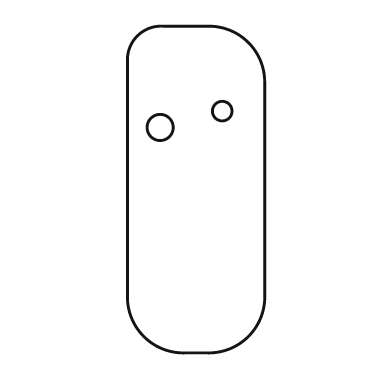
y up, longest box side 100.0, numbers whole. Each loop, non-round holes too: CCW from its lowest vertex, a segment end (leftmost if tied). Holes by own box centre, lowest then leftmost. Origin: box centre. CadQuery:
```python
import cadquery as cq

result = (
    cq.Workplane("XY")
    .moveTo(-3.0, -50.0)
    .lineTo(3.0, -50.0)
    .threePointArc((16.0, -45.0), (21.0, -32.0))
    .lineTo(21.0, 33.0)
    .threePointArc((16.0, 45.0), (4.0, 50.0))
    .lineTo(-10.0, 50.0)
    .threePointArc((-18.0, 47.0), (-21.0, 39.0))
    .lineTo(-21.0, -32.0)
    .threePointArc((-16.0, -45.0), (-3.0, -50.0))
    .close()
    .moveTo(-11.0, 19.0)
    .circle(4.0)
    .moveTo(8.0, 24.0)
    .circle(3.0)
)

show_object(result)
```